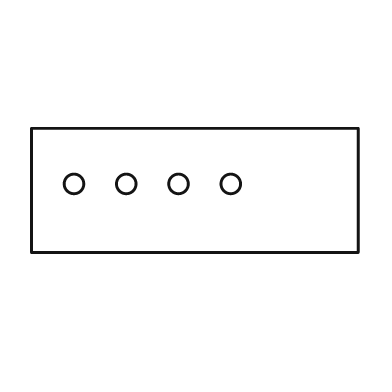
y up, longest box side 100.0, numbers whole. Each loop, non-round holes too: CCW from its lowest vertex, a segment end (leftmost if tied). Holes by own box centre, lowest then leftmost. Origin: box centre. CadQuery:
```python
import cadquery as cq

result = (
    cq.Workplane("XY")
    .moveTo(-50.0, -19.0)
    .lineTo(50.0, -19.0)
    .lineTo(50.0, 19.0)
    .lineTo(-50.0, 19.0)
    .close()
    .moveTo(-37.0, 2.0)
    .circle(3.0)
    .moveTo(-21.0, 2.0)
    .circle(3.0)
    .moveTo(-5.0, 2.0)
    .circle(3.0)
    .moveTo(11.0, 2.0)
    .circle(3.0)
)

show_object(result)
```